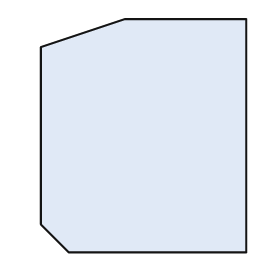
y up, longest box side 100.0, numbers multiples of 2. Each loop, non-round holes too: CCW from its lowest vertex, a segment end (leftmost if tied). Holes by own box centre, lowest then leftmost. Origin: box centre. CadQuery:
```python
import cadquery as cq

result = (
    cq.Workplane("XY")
    .moveTo(-32.0, -50.0)
    .lineTo(44.0, -50.0)
    .lineTo(44.0, 50.0)
    .lineTo(-8.0, 50.0)
    .lineTo(-44.0, 38.0)
    .lineTo(-44.0, -38.0)
    .close()
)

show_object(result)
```